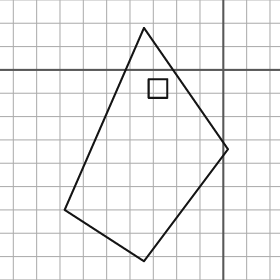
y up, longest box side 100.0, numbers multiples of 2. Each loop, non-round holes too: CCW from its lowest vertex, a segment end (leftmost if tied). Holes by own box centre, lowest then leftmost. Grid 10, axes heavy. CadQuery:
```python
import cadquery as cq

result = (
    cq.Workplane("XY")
    .moveTo(-34.0, -82.0)
    .lineTo(2.0, -34.0)
    .lineTo(-34.0, 18.0)
    .lineTo(-68.0, -60.0)
    .close()
    .moveTo(-32.0, -12.0)
    .lineTo(-24.0, -12.0)
    .lineTo(-24.0, -4.0)
    .lineTo(-32.0, -4.0)
    .close()
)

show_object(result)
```